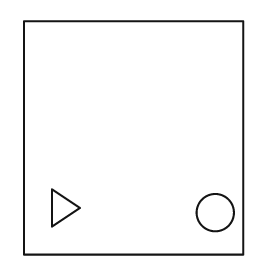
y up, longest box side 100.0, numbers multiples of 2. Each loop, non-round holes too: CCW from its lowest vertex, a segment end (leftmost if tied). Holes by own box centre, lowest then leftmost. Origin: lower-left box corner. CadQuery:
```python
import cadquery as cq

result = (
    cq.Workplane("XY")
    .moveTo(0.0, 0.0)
    .lineTo(94.0, 0.0)
    .lineTo(94.0, 100.0)
    .lineTo(0.0, 100.0)
    .close()
    .moveTo(82.0, 18.0)
    .circle(8.0)
    .moveTo(12.0, 12.0)
    .lineTo(24.0, 20.0)
    .lineTo(12.0, 28.0)
    .close()
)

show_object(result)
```